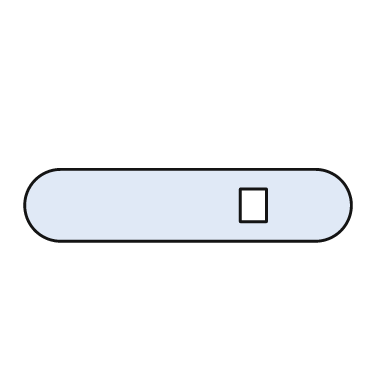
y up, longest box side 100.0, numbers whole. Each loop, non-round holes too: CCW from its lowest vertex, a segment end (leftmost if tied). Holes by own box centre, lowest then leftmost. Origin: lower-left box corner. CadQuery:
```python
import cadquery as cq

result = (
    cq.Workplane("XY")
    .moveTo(11.0, 0.0)
    .lineTo(89.0, 0.0)
    .threePointArc((100.0, 11.0), (89.0, 22.0))
    .lineTo(11.0, 22.0)
    .threePointArc((0.0, 11.0), (11.0, 0.0))
    .close()
    .moveTo(66.0, 6.0)
    .lineTo(74.0, 6.0)
    .lineTo(74.0, 16.0)
    .lineTo(66.0, 16.0)
    .close()
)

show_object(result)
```